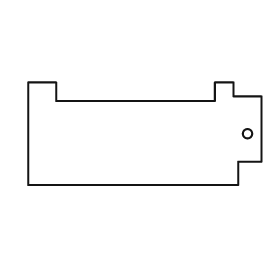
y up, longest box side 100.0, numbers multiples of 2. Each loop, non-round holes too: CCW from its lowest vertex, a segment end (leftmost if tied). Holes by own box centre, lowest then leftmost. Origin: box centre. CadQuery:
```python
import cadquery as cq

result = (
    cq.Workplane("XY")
    .moveTo(-50.0, -22.0)
    .lineTo(40.0, -22.0)
    .lineTo(40.0, -12.0)
    .lineTo(50.0, -12.0)
    .lineTo(50.0, 16.0)
    .lineTo(38.0, 16.0)
    .lineTo(38.0, 22.0)
    .lineTo(30.0, 22.0)
    .lineTo(30.0, 14.0)
    .lineTo(-38.0, 14.0)
    .lineTo(-38.0, 22.0)
    .lineTo(-50.0, 22.0)
    .close()
    .moveTo(44.0, 0.0)
    .circle(2.0)
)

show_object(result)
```